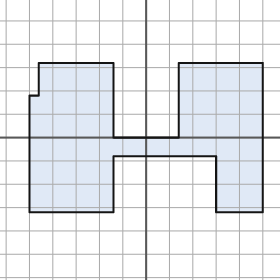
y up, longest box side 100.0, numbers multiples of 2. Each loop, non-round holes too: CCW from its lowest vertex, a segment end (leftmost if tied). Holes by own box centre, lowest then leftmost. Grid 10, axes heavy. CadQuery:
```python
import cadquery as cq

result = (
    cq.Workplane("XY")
    .moveTo(-50.0, -32.0)
    .lineTo(-14.0, -32.0)
    .lineTo(-14.0, -8.0)
    .lineTo(30.0, -8.0)
    .lineTo(30.0, -32.0)
    .lineTo(50.0, -32.0)
    .lineTo(50.0, 32.0)
    .lineTo(14.0, 32.0)
    .lineTo(14.0, 0.0)
    .lineTo(-14.0, 0.0)
    .lineTo(-14.0, 32.0)
    .lineTo(-46.0, 32.0)
    .lineTo(-46.0, 18.0)
    .lineTo(-50.0, 18.0)
    .close()
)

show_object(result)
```